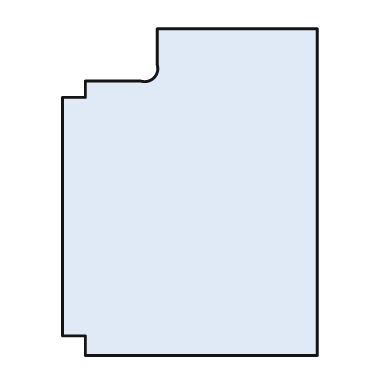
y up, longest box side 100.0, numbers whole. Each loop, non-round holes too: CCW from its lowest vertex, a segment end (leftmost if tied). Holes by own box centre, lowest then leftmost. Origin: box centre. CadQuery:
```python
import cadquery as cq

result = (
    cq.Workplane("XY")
    .moveTo(-32.0, -50.0)
    .lineTo(39.0, -50.0)
    .lineTo(39.0, 50.0)
    .lineTo(-10.0, 50.0)
    .lineTo(-10.0, 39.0)
    .threePointArc((-11.0, 35.0), (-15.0, 34.0))
    .lineTo(-32.0, 34.0)
    .lineTo(-32.0, 29.0)
    .lineTo(-39.0, 29.0)
    .lineTo(-39.0, -44.0)
    .lineTo(-32.0, -44.0)
    .close()
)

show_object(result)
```